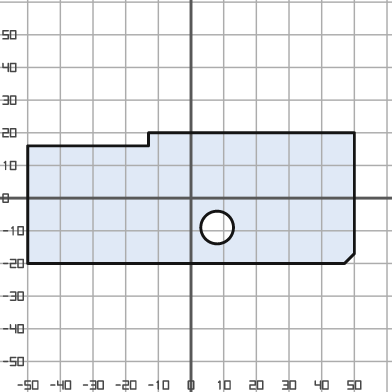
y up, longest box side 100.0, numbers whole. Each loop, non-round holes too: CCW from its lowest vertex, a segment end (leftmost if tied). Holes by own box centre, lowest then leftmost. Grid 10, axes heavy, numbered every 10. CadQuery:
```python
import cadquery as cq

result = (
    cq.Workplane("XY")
    .moveTo(-50.0, -20.0)
    .lineTo(47.0, -20.0)
    .lineTo(50.0, -17.0)
    .lineTo(50.0, 20.0)
    .lineTo(-13.0, 20.0)
    .lineTo(-13.0, 16.0)
    .lineTo(-50.0, 16.0)
    .close()
    .moveTo(8.0, -9.0)
    .circle(5.0)
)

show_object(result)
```